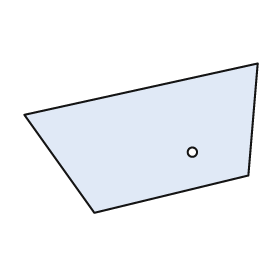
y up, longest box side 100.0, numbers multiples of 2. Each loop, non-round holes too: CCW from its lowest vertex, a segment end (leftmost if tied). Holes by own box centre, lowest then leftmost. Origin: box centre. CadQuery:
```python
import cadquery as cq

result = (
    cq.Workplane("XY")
    .moveTo(-20.0, -32.0)
    .lineTo(46.0, -16.0)
    .lineTo(50.0, 32.0)
    .lineTo(-50.0, 10.0)
    .close()
    .moveTo(22.0, -6.0)
    .circle(2.0)
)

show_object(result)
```